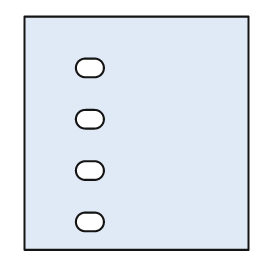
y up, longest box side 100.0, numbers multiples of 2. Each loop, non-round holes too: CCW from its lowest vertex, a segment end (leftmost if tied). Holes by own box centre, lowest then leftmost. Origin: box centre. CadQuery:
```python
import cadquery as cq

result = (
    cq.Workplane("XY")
    .moveTo(-48.0, -50.0)
    .lineTo(48.0, -50.0)
    .lineTo(48.0, 50.0)
    .lineTo(-48.0, 50.0)
    .close()
    .moveTo(-22.0, -42.0)
    .lineTo(-18.0, -42.0)
    .threePointArc((-14.0, -38.0), (-18.0, -34.0))
    .lineTo(-22.0, -34.0)
    .threePointArc((-26.0, -38.0), (-22.0, -42.0))
    .close()
    .moveTo(-22.0, -20.0)
    .lineTo(-18.0, -20.0)
    .threePointArc((-14.0, -16.0), (-18.0, -12.0))
    .lineTo(-22.0, -12.0)
    .threePointArc((-26.0, -16.0), (-22.0, -20.0))
    .close()
    .moveTo(-22.0, 2.0)
    .lineTo(-18.0, 2.0)
    .threePointArc((-14.0, 6.0), (-18.0, 10.0))
    .lineTo(-22.0, 10.0)
    .threePointArc((-26.0, 6.0), (-22.0, 2.0))
    .close()
    .moveTo(-22.0, 24.0)
    .lineTo(-18.0, 24.0)
    .threePointArc((-14.0, 28.0), (-18.0, 32.0))
    .lineTo(-22.0, 32.0)
    .threePointArc((-26.0, 28.0), (-22.0, 24.0))
    .close()
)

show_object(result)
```